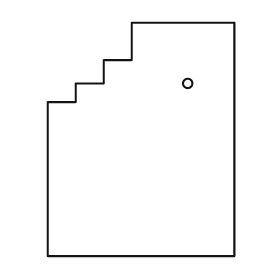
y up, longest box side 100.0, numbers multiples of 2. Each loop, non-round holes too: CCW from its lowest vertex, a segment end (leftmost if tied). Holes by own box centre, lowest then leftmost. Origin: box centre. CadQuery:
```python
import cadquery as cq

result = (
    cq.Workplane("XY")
    .moveTo(-40.0, -50.0)
    .lineTo(40.0, -50.0)
    .lineTo(40.0, 50.0)
    .lineTo(-4.0, 50.0)
    .lineTo(-4.0, 34.0)
    .lineTo(-16.0, 34.0)
    .lineTo(-16.0, 24.0)
    .lineTo(-28.0, 24.0)
    .lineTo(-28.0, 16.0)
    .lineTo(-40.0, 16.0)
    .close()
    .moveTo(20.0, 24.0)
    .circle(2.0)
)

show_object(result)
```